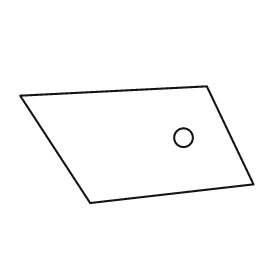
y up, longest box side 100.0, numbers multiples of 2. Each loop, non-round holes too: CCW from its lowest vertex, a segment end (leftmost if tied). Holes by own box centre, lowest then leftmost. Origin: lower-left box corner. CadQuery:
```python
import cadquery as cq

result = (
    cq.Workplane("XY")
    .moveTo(30.0, 0.0)
    .lineTo(100.0, 8.0)
    .lineTo(80.0, 50.0)
    .lineTo(0.0, 46.0)
    .close()
    .moveTo(70.0, 28.0)
    .circle(4.0)
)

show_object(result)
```